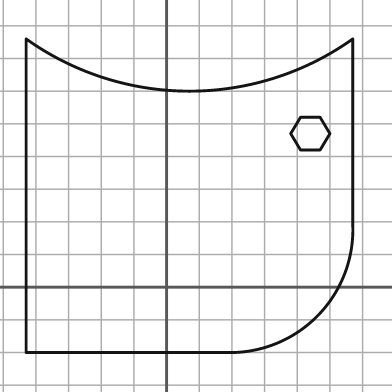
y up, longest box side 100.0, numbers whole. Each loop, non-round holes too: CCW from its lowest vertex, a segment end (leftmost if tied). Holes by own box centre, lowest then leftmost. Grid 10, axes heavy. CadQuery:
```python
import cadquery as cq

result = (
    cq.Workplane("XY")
    .moveTo(-43.0, -20.0)
    .lineTo(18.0, -20.0)
    .threePointArc((46.0, -9.0), (57.0, 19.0))
    .lineTo(57.0, 76.0)
    .threePointArc((7.0, 60.0), (-43.0, 76.0))
    .close()
    .moveTo(41.0, 42.0)
    .lineTo(47.0, 42.0)
    .lineTo(50.0, 47.0)
    .lineTo(47.0, 52.0)
    .lineTo(41.0, 52.0)
    .lineTo(38.0, 47.0)
    .close()
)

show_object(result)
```